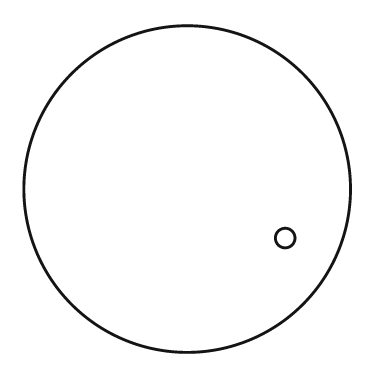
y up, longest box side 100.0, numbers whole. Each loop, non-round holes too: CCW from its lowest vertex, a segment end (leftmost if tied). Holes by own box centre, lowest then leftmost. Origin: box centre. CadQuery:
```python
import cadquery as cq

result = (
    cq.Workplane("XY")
    .moveTo(0.0, 0.0)
    .circle(50.0)
    .moveTo(30.0, -15.0)
    .circle(3.0)
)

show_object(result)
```